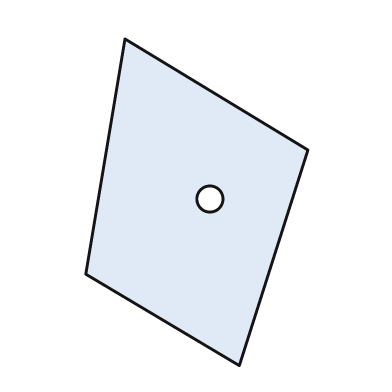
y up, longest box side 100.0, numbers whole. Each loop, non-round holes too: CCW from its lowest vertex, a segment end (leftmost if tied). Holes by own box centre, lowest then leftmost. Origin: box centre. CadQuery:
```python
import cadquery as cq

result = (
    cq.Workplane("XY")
    .moveTo(13.0, -50.0)
    .lineTo(34.0, 16.0)
    .lineTo(-22.0, 50.0)
    .lineTo(-34.0, -22.0)
    .close()
    .moveTo(4.0, 1.0)
    .circle(4.0)
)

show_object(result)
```